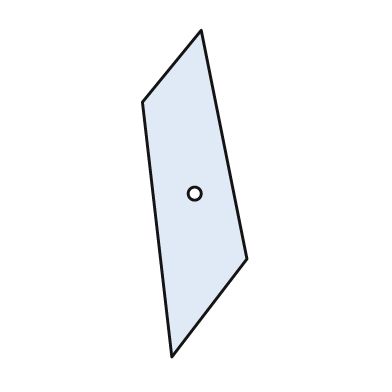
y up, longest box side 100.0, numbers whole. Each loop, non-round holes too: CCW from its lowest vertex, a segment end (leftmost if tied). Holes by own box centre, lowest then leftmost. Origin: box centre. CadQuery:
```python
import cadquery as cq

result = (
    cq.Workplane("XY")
    .moveTo(-7.0, -50.0)
    .lineTo(16.0, -20.0)
    .lineTo(2.0, 50.0)
    .lineTo(-16.0, 28.0)
    .close()
    .moveTo(0.0, 0.0)
    .circle(2.0)
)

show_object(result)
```